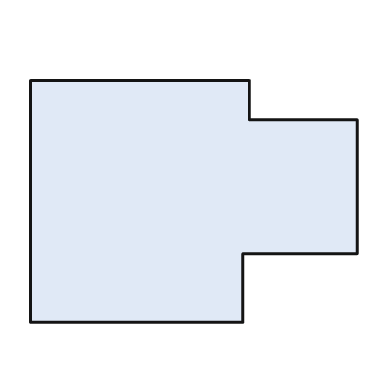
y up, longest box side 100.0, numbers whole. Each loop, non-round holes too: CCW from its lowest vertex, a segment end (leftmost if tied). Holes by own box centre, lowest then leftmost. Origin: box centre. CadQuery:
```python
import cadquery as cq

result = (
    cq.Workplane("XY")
    .moveTo(-50.0, -37.0)
    .lineTo(15.0, -37.0)
    .lineTo(15.0, -16.0)
    .lineTo(50.0, -16.0)
    .lineTo(50.0, 25.0)
    .lineTo(17.0, 25.0)
    .lineTo(17.0, 37.0)
    .lineTo(-50.0, 37.0)
    .close()
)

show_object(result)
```